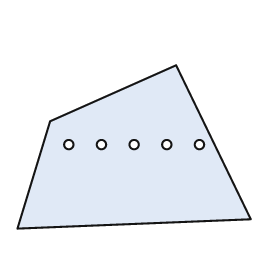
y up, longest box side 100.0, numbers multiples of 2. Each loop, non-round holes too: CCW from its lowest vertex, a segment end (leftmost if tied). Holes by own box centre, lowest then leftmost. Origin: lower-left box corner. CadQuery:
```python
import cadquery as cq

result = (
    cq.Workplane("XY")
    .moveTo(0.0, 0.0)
    .lineTo(100.0, 4.0)
    .lineTo(68.0, 70.0)
    .lineTo(14.0, 46.0)
    .close()
    .moveTo(22.0, 36.0)
    .circle(2.0)
    .moveTo(36.0, 36.0)
    .circle(2.0)
    .moveTo(50.0, 36.0)
    .circle(2.0)
    .moveTo(64.0, 36.0)
    .circle(2.0)
    .moveTo(78.0, 36.0)
    .circle(2.0)
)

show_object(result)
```